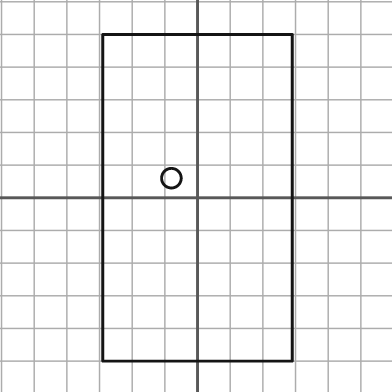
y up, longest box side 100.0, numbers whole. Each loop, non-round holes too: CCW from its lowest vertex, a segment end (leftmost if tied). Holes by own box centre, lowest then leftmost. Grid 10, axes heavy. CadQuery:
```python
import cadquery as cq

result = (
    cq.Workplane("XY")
    .moveTo(-29.0, -50.0)
    .lineTo(29.0, -50.0)
    .lineTo(29.0, 50.0)
    .lineTo(-29.0, 50.0)
    .close()
    .moveTo(-8.0, 6.0)
    .circle(3.0)
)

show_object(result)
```